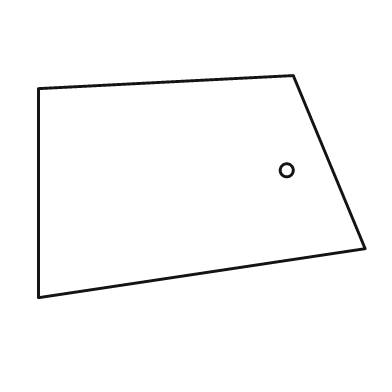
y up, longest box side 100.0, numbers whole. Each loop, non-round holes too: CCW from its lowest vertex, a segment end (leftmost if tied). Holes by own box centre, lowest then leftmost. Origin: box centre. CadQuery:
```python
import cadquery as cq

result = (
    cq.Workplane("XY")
    .moveTo(-50.0, -34.0)
    .lineTo(50.0, -19.0)
    .lineTo(28.0, 34.0)
    .lineTo(-50.0, 30.0)
    .close()
    .moveTo(26.0, 5.0)
    .circle(2.0)
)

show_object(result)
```